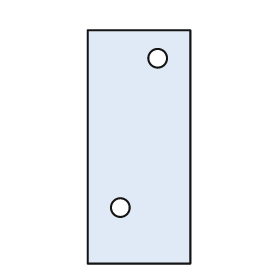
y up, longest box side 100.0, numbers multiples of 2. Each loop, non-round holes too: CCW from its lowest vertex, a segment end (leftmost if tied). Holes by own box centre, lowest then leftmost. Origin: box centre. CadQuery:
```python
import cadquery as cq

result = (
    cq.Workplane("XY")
    .moveTo(-22.0, -50.0)
    .lineTo(22.0, -50.0)
    .lineTo(22.0, 50.0)
    .lineTo(-22.0, 50.0)
    .close()
    .moveTo(-8.0, -26.0)
    .circle(4.0)
    .moveTo(8.0, 38.0)
    .circle(4.0)
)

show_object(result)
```